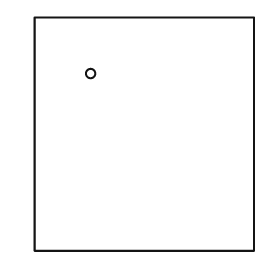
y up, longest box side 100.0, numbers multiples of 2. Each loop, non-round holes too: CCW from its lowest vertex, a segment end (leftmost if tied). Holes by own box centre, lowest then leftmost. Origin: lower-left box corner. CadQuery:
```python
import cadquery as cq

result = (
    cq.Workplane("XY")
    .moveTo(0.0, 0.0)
    .lineTo(94.0, 0.0)
    .lineTo(94.0, 100.0)
    .lineTo(0.0, 100.0)
    .close()
    .moveTo(24.0, 76.0)
    .circle(2.0)
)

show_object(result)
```